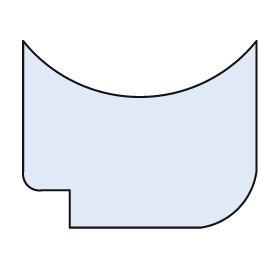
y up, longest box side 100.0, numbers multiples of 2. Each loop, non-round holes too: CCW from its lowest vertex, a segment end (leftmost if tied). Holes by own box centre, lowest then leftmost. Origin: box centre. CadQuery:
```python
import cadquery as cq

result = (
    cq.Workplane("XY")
    .moveTo(-30.0, -40.0)
    .lineTo(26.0, -40.0)
    .threePointArc((42.0, -32.0), (50.0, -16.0))
    .lineTo(50.0, 40.0)
    .threePointArc((0.0, 16.0), (-50.0, 40.0))
    .lineTo(-50.0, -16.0)
    .threePointArc((-48.0, -22.0), (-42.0, -24.0))
    .lineTo(-30.0, -24.0)
    .close()
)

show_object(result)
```